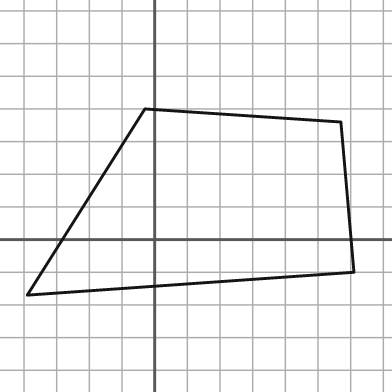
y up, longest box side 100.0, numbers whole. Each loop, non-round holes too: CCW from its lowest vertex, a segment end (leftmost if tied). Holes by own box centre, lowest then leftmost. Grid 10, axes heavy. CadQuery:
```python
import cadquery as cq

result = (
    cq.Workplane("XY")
    .moveTo(-39.0, -17.0)
    .lineTo(61.0, -10.0)
    .lineTo(57.0, 36.0)
    .lineTo(-3.0, 40.0)
    .close()
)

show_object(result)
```